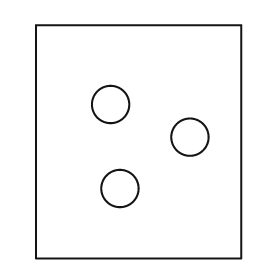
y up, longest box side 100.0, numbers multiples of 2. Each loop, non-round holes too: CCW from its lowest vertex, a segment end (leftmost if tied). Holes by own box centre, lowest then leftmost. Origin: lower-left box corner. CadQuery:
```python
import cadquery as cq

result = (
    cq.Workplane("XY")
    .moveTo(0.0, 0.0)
    .lineTo(88.0, 0.0)
    .lineTo(88.0, 100.0)
    .lineTo(0.0, 100.0)
    .close()
    .moveTo(36.0, 30.0)
    .circle(8.0)
    .moveTo(66.0, 52.0)
    .circle(8.0)
    .moveTo(32.0, 66.0)
    .circle(8.0)
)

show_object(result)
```